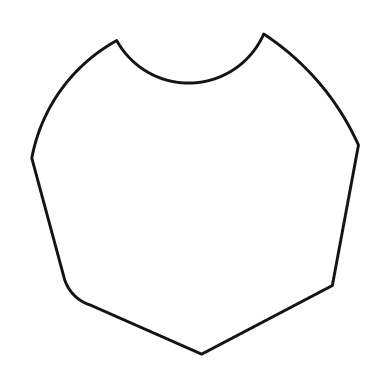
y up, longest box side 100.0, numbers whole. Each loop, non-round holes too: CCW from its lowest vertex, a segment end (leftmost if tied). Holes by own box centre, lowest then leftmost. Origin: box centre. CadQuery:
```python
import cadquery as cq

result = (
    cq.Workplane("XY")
    .moveTo(2.0, -49.0)
    .lineTo(42.0, -28.0)
    .lineTo(50.0, 15.0)
    .threePointArc((38.0, 34.0), (21.0, 49.0))
    .threePointArc((-1.0, 34.0), (-24.0, 47.0))
    .threePointArc((-41.0, 32.0), (-50.0, 11.0))
    .lineTo(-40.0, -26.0)
    .threePointArc((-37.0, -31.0), (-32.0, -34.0))
    .close()
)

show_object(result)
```